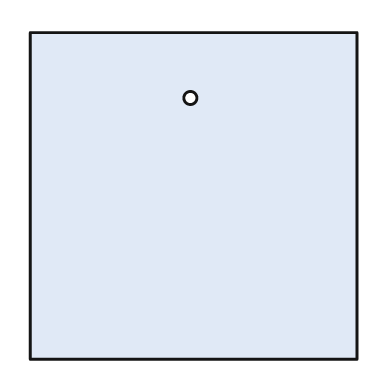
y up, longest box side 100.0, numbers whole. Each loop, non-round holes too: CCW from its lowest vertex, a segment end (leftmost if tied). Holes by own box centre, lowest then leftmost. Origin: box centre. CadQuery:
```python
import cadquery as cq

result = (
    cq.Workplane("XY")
    .moveTo(-50.0, -50.0)
    .lineTo(50.0, -50.0)
    .lineTo(50.0, 50.0)
    .lineTo(-50.0, 50.0)
    .close()
    .moveTo(-1.0, 30.0)
    .circle(2.0)
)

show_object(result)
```